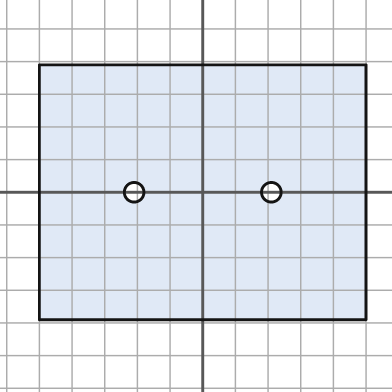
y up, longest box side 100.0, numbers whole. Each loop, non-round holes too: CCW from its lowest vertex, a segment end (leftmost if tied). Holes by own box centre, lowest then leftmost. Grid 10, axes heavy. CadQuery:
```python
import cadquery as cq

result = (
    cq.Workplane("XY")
    .moveTo(-50.0, -39.0)
    .lineTo(50.0, -39.0)
    .lineTo(50.0, 39.0)
    .lineTo(-50.0, 39.0)
    .close()
    .moveTo(-21.0, 0.0)
    .circle(3.0)
    .moveTo(21.0, 0.0)
    .circle(3.0)
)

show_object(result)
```